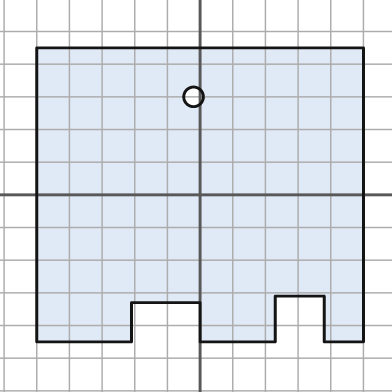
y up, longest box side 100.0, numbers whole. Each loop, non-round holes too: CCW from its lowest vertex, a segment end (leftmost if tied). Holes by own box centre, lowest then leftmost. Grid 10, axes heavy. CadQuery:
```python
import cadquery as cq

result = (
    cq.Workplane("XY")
    .moveTo(-50.0, -45.0)
    .lineTo(-21.0, -45.0)
    .lineTo(-21.0, -33.0)
    .lineTo(0.0, -33.0)
    .lineTo(0.0, -45.0)
    .lineTo(23.0, -45.0)
    .lineTo(23.0, -31.0)
    .lineTo(38.0, -31.0)
    .lineTo(38.0, -45.0)
    .lineTo(50.0, -45.0)
    .lineTo(50.0, 45.0)
    .lineTo(-50.0, 45.0)
    .close()
    .moveTo(-2.0, 30.0)
    .circle(3.0)
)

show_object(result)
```